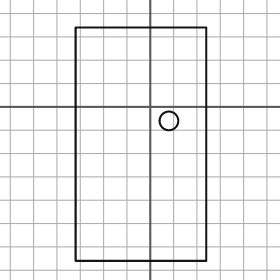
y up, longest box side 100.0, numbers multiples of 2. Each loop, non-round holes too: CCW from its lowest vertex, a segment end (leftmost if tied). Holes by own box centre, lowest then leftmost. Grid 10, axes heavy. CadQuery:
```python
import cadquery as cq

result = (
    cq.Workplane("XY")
    .moveTo(-32.0, -66.0)
    .lineTo(24.0, -66.0)
    .lineTo(24.0, 34.0)
    .lineTo(-32.0, 34.0)
    .close()
    .moveTo(8.0, -6.0)
    .circle(4.0)
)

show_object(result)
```